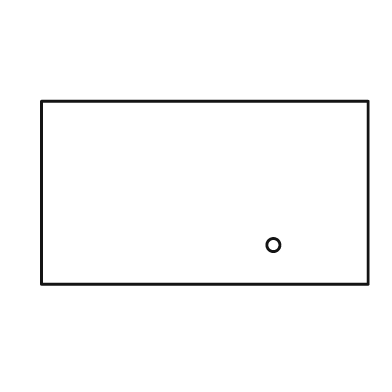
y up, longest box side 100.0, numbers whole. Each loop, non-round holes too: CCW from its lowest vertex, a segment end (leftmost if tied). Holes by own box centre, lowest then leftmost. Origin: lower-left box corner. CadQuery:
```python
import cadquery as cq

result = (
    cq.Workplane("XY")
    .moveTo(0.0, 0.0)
    .lineTo(100.0, 0.0)
    .lineTo(100.0, 56.0)
    .lineTo(0.0, 56.0)
    .close()
    .moveTo(71.0, 12.0)
    .circle(2.0)
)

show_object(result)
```